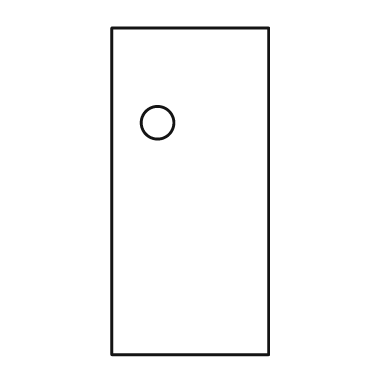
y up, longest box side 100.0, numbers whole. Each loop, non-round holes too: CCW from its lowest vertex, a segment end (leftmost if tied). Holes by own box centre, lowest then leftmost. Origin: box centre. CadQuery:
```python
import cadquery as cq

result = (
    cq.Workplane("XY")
    .moveTo(-24.0, -50.0)
    .lineTo(24.0, -50.0)
    .lineTo(24.0, 50.0)
    .lineTo(-24.0, 50.0)
    .close()
    .moveTo(-10.0, 21.0)
    .circle(5.0)
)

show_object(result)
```